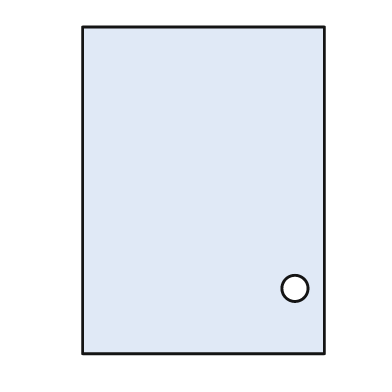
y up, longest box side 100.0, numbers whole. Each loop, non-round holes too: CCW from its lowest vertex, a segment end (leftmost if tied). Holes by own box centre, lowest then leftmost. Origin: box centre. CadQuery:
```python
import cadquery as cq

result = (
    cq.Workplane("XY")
    .moveTo(-37.0, -50.0)
    .lineTo(37.0, -50.0)
    .lineTo(37.0, 50.0)
    .lineTo(-37.0, 50.0)
    .close()
    .moveTo(28.0, -30.0)
    .circle(4.0)
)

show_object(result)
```